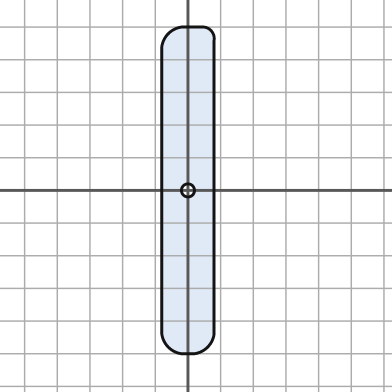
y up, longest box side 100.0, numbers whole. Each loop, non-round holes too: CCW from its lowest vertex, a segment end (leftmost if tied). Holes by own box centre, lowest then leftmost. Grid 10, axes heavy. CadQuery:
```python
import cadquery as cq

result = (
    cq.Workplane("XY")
    .moveTo(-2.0, -50.0)
    .lineTo(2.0, -50.0)
    .threePointArc((6.0, -48.0), (8.0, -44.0))
    .lineTo(8.0, 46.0)
    .threePointArc((7.0, 49.0), (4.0, 50.0))
    .lineTo(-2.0, 50.0)
    .threePointArc((-6.0, 48.0), (-8.0, 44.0))
    .lineTo(-8.0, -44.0)
    .threePointArc((-6.0, -48.0), (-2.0, -50.0))
    .close()
    .moveTo(0.0, 0.0)
    .circle(2.0)
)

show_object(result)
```